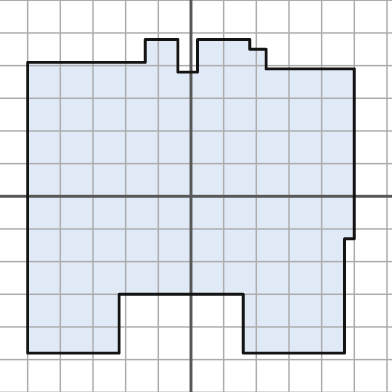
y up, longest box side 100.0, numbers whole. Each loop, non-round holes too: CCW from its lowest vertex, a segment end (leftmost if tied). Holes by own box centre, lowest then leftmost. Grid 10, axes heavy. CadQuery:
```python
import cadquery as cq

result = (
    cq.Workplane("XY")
    .moveTo(-50.0, -48.0)
    .lineTo(-22.0, -48.0)
    .lineTo(-22.0, -30.0)
    .lineTo(16.0, -30.0)
    .lineTo(16.0, -48.0)
    .lineTo(47.0, -48.0)
    .lineTo(47.0, -13.0)
    .lineTo(50.0, -13.0)
    .lineTo(50.0, 39.0)
    .lineTo(23.0, 39.0)
    .lineTo(23.0, 45.0)
    .lineTo(18.0, 45.0)
    .lineTo(18.0, 48.0)
    .lineTo(2.0, 48.0)
    .lineTo(2.0, 38.0)
    .lineTo(-4.0, 38.0)
    .lineTo(-4.0, 48.0)
    .lineTo(-14.0, 48.0)
    .lineTo(-14.0, 41.0)
    .lineTo(-50.0, 41.0)
    .close()
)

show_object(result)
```